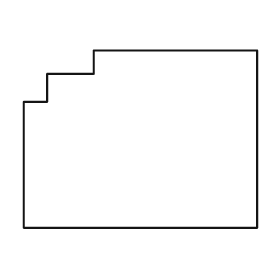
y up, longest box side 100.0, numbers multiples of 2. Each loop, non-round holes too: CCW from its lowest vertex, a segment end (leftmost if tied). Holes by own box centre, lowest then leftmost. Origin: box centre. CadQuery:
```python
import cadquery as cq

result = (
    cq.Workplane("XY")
    .moveTo(-50.0, -38.0)
    .lineTo(50.0, -38.0)
    .lineTo(50.0, 38.0)
    .lineTo(-20.0, 38.0)
    .lineTo(-20.0, 28.0)
    .lineTo(-40.0, 28.0)
    .lineTo(-40.0, 16.0)
    .lineTo(-50.0, 16.0)
    .close()
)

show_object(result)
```